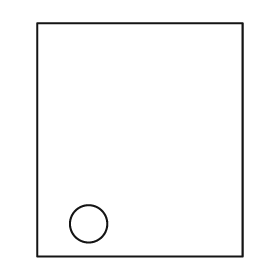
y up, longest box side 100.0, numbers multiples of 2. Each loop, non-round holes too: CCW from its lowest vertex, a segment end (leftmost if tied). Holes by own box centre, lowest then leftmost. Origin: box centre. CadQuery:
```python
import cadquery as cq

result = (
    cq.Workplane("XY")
    .moveTo(-44.0, -50.0)
    .lineTo(44.0, -50.0)
    .lineTo(44.0, 50.0)
    .lineTo(-44.0, 50.0)
    .close()
    .moveTo(-22.0, -36.0)
    .circle(8.0)
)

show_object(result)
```